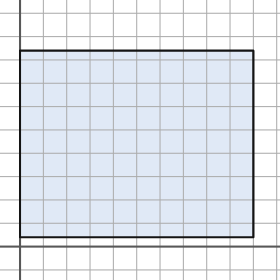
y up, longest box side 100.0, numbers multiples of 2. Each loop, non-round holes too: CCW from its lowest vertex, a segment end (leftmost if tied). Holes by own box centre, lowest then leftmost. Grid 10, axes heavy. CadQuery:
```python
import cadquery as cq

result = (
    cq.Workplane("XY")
    .moveTo(0.0, 4.0)
    .lineTo(100.0, 4.0)
    .lineTo(100.0, 84.0)
    .lineTo(0.0, 84.0)
    .close()
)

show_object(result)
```